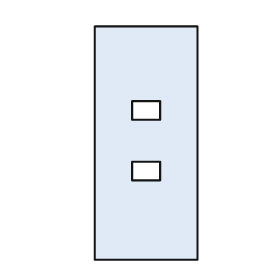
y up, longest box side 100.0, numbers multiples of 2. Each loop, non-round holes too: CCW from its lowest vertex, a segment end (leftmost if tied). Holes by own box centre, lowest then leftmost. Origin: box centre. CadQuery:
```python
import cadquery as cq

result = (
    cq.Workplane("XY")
    .moveTo(-22.0, -50.0)
    .lineTo(22.0, -50.0)
    .lineTo(22.0, 50.0)
    .lineTo(-22.0, 50.0)
    .close()
    .moveTo(-6.0, -16.0)
    .lineTo(6.0, -16.0)
    .lineTo(6.0, -8.0)
    .lineTo(-6.0, -8.0)
    .close()
    .moveTo(-6.0, 10.0)
    .lineTo(6.0, 10.0)
    .lineTo(6.0, 18.0)
    .lineTo(-6.0, 18.0)
    .close()
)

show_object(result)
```